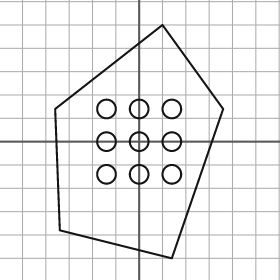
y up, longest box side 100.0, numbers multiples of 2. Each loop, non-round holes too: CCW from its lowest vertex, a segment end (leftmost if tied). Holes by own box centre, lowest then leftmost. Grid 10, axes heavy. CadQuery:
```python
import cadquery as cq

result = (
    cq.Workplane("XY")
    .moveTo(14.0, -50.0)
    .lineTo(36.0, 14.0)
    .lineTo(10.0, 50.0)
    .lineTo(-36.0, 14.0)
    .lineTo(-34.0, -38.0)
    .close()
    .moveTo(-14.0, -14.0)
    .circle(4.0)
    .moveTo(0.0, -14.0)
    .circle(4.0)
    .moveTo(14.0, -14.0)
    .circle(4.0)
    .moveTo(-14.0, 0.0)
    .circle(4.0)
    .moveTo(0.0, 0.0)
    .circle(4.0)
    .moveTo(14.0, 0.0)
    .circle(4.0)
    .moveTo(-14.0, 14.0)
    .circle(4.0)
    .moveTo(0.0, 14.0)
    .circle(4.0)
    .moveTo(14.0, 14.0)
    .circle(4.0)
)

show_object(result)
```